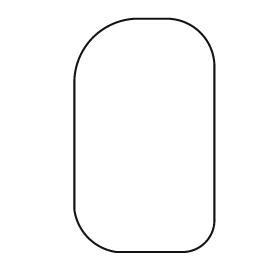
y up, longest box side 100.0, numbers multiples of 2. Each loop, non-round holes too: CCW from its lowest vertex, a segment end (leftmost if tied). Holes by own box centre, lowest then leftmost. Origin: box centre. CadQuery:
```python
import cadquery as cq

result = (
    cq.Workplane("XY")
    .moveTo(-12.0, -50.0)
    .lineTo(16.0, -50.0)
    .threePointArc((26.0, -46.0), (30.0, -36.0))
    .lineTo(30.0, 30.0)
    .threePointArc((24.0, 44.0), (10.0, 50.0))
    .lineTo(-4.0, 50.0)
    .threePointArc((-22.0, 42.0), (-30.0, 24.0))
    .lineTo(-30.0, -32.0)
    .threePointArc((-24.0, -44.0), (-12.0, -50.0))
    .close()
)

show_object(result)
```